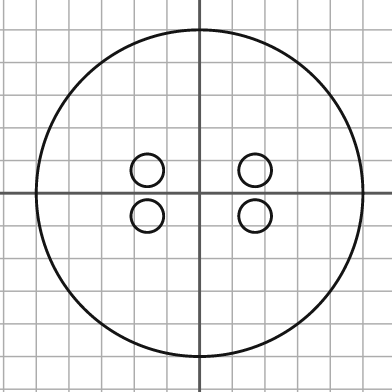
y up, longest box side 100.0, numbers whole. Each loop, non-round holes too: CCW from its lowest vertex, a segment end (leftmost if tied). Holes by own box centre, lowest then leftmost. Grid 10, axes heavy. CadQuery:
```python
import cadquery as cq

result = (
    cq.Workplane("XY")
    .moveTo(0.0, 0.0)
    .circle(50.0)
    .moveTo(-16.0, -7.0)
    .circle(5.0)
    .moveTo(17.0, -7.0)
    .circle(5.0)
    .moveTo(-16.0, 7.0)
    .circle(5.0)
    .moveTo(17.0, 7.0)
    .circle(5.0)
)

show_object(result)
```